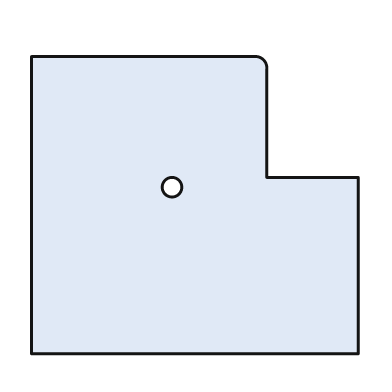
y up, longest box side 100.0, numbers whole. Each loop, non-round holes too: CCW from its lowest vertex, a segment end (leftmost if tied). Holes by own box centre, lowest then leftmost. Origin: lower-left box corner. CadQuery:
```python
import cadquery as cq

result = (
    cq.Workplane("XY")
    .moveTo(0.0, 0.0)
    .lineTo(100.0, 0.0)
    .lineTo(100.0, 54.0)
    .lineTo(72.0, 54.0)
    .lineTo(72.0, 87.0)
    .threePointArc((71.0, 90.0), (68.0, 91.0))
    .lineTo(0.0, 91.0)
    .close()
    .moveTo(43.0, 51.0)
    .circle(3.0)
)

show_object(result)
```